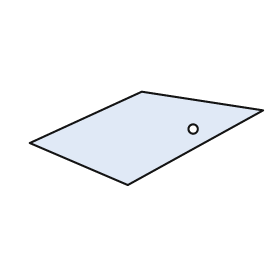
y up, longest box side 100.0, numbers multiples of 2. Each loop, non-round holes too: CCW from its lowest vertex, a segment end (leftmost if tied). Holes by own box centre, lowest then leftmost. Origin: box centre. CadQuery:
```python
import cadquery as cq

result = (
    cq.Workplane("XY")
    .moveTo(-8.0, -20.0)
    .lineTo(50.0, 12.0)
    .lineTo(-2.0, 20.0)
    .lineTo(-50.0, -2.0)
    .close()
    .moveTo(20.0, 4.0)
    .circle(2.0)
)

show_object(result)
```